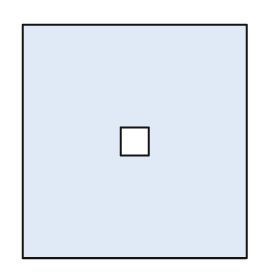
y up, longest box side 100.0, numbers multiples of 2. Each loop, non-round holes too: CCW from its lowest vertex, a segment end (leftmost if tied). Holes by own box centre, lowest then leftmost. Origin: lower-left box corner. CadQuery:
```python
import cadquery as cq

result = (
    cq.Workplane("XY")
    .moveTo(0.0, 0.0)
    .lineTo(96.0, 0.0)
    .lineTo(96.0, 100.0)
    .lineTo(0.0, 100.0)
    .close()
    .moveTo(42.0, 44.0)
    .lineTo(54.0, 44.0)
    .lineTo(54.0, 56.0)
    .lineTo(42.0, 56.0)
    .close()
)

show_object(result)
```